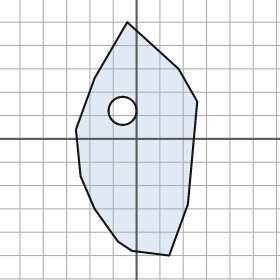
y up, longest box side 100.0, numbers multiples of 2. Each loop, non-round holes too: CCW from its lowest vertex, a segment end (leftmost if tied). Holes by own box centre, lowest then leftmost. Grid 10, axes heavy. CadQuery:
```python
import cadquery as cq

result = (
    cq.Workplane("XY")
    .moveTo(14.0, -50.0)
    .lineTo(22.0, -28.0)
    .lineTo(26.0, 16.0)
    .lineTo(18.0, 30.0)
    .lineTo(-4.0, 50.0)
    .lineTo(-18.0, 26.0)
    .lineTo(-26.0, 4.0)
    .lineTo(-24.0, -16.0)
    .lineTo(-18.0, -30.0)
    .lineTo(-8.0, -44.0)
    .lineTo(-2.0, -48.0)
    .close()
    .moveTo(-6.0, 12.0)
    .circle(6.0)
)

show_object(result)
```